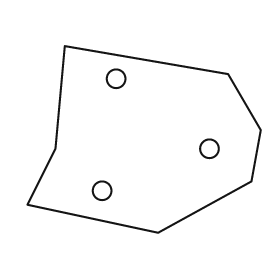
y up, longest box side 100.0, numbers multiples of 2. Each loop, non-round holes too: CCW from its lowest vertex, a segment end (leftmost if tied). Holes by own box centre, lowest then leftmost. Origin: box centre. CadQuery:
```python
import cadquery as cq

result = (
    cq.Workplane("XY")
    .moveTo(6.0, -40.0)
    .lineTo(46.0, -18.0)
    .lineTo(50.0, 4.0)
    .lineTo(36.0, 28.0)
    .lineTo(-34.0, 40.0)
    .lineTo(-38.0, -4.0)
    .lineTo(-50.0, -28.0)
    .close()
    .moveTo(-18.0, -22.0)
    .circle(4.0)
    .moveTo(28.0, -4.0)
    .circle(4.0)
    .moveTo(-12.0, 26.0)
    .circle(4.0)
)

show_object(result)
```